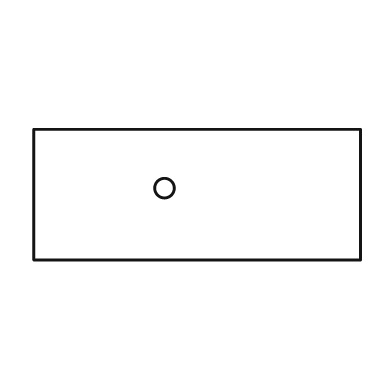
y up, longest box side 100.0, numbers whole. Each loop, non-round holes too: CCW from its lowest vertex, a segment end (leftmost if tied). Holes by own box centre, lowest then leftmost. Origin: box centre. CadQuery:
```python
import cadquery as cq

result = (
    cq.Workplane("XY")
    .moveTo(-50.0, -20.0)
    .lineTo(50.0, -20.0)
    .lineTo(50.0, 20.0)
    .lineTo(-50.0, 20.0)
    .close()
    .moveTo(-10.0, 2.0)
    .circle(3.0)
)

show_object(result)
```